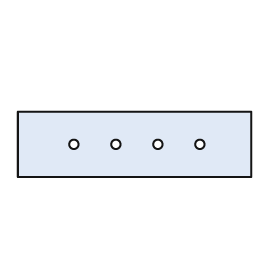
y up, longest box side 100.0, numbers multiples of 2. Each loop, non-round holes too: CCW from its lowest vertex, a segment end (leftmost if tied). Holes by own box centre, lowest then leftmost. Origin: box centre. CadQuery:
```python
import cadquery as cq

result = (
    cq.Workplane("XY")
    .moveTo(-50.0, -14.0)
    .lineTo(50.0, -14.0)
    .lineTo(50.0, 14.0)
    .lineTo(-50.0, 14.0)
    .close()
    .moveTo(-26.0, 0.0)
    .circle(2.0)
    .moveTo(-8.0, 0.0)
    .circle(2.0)
    .moveTo(10.0, 0.0)
    .circle(2.0)
    .moveTo(28.0, 0.0)
    .circle(2.0)
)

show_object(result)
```